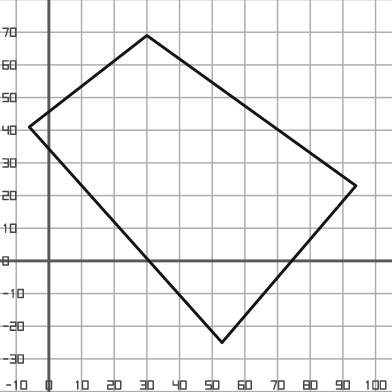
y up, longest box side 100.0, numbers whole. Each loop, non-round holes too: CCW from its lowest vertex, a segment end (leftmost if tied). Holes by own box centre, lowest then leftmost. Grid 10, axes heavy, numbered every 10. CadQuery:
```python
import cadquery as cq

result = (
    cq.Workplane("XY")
    .moveTo(53.0, -25.0)
    .lineTo(94.0, 23.0)
    .lineTo(30.0, 69.0)
    .lineTo(-6.0, 41.0)
    .close()
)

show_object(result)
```